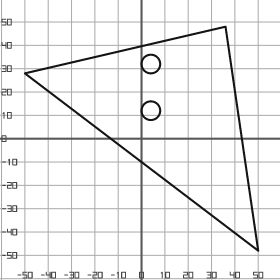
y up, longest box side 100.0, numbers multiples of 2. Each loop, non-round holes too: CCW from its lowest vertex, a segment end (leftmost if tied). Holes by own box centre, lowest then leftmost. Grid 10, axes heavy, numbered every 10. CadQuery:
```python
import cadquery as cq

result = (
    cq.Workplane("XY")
    .moveTo(50.0, -48.0)
    .lineTo(36.0, 48.0)
    .lineTo(-50.0, 28.0)
    .close()
    .moveTo(4.0, 12.0)
    .circle(4.0)
    .moveTo(4.0, 32.0)
    .circle(4.0)
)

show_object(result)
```